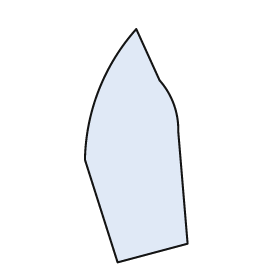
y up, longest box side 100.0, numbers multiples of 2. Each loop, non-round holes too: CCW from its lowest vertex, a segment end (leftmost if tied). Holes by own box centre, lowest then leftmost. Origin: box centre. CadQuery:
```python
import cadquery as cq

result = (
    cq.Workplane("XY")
    .moveTo(-8.0, -50.0)
    .lineTo(22.0, -42.0)
    .lineTo(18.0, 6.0)
    .threePointArc((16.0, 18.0), (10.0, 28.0))
    .lineTo(0.0, 50.0)
    .threePointArc((-16.0, 24.0), (-22.0, -6.0))
    .close()
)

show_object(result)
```